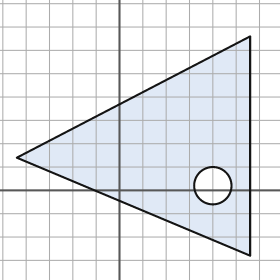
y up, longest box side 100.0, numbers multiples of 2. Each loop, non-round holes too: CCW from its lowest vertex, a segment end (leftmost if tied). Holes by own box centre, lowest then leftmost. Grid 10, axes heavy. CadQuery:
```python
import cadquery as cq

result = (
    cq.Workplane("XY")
    .moveTo(56.0, -28.0)
    .lineTo(56.0, 66.0)
    .lineTo(-44.0, 14.0)
    .close()
    .moveTo(40.0, 2.0)
    .circle(8.0)
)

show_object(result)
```